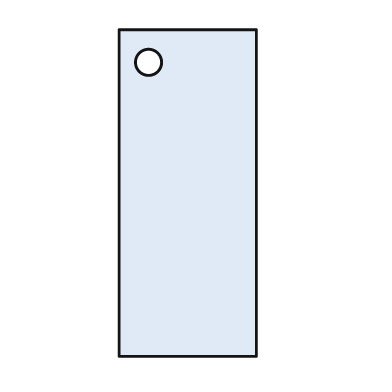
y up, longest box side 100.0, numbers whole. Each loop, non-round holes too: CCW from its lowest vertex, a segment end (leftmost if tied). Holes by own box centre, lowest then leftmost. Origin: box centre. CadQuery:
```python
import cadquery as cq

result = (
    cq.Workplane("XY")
    .moveTo(-21.0, -50.0)
    .lineTo(21.0, -50.0)
    .lineTo(21.0, 50.0)
    .lineTo(-21.0, 50.0)
    .close()
    .moveTo(-12.0, 40.0)
    .circle(4.0)
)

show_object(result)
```